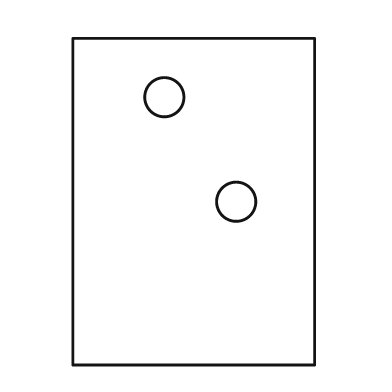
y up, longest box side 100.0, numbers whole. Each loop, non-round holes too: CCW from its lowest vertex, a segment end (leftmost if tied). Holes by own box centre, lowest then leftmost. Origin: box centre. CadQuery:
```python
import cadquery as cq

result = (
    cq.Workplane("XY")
    .moveTo(-37.0, -50.0)
    .lineTo(37.0, -50.0)
    .lineTo(37.0, 50.0)
    .lineTo(-37.0, 50.0)
    .close()
    .moveTo(13.0, 0.0)
    .circle(6.0)
    .moveTo(-9.0, 32.0)
    .circle(6.0)
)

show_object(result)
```